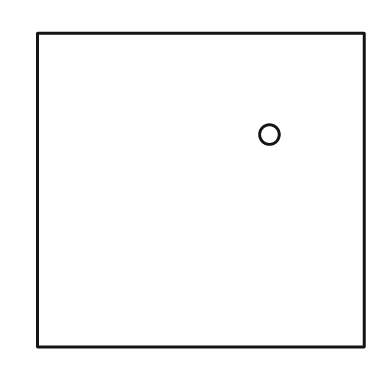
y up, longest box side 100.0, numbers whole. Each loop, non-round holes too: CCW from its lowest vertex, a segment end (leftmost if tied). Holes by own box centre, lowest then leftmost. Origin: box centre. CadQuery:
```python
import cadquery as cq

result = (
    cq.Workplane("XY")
    .moveTo(-50.0, -48.0)
    .lineTo(50.0, -48.0)
    .lineTo(50.0, 48.0)
    .lineTo(-50.0, 48.0)
    .close()
    .moveTo(21.0, 17.0)
    .circle(3.0)
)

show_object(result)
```